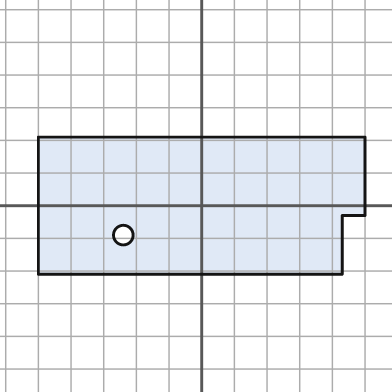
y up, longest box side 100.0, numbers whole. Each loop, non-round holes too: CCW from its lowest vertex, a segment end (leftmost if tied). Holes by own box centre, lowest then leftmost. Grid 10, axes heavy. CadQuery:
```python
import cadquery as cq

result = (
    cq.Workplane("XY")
    .moveTo(-50.0, -21.0)
    .lineTo(43.0, -21.0)
    .lineTo(43.0, -3.0)
    .lineTo(50.0, -3.0)
    .lineTo(50.0, 21.0)
    .lineTo(-50.0, 21.0)
    .close()
    .moveTo(-24.0, -9.0)
    .circle(3.0)
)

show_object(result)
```